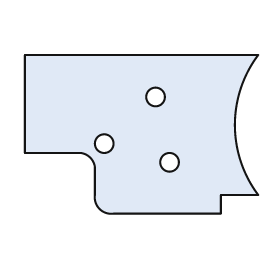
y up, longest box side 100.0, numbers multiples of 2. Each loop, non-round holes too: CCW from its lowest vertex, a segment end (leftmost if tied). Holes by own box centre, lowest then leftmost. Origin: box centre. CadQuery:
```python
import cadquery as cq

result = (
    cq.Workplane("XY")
    .moveTo(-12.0, -34.0)
    .lineTo(34.0, -34.0)
    .lineTo(34.0, -26.0)
    .lineTo(50.0, -26.0)
    .threePointArc((40.0, 4.0), (50.0, 34.0))
    .lineTo(-50.0, 34.0)
    .lineTo(-50.0, -8.0)
    .lineTo(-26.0, -8.0)
    .threePointArc((-22.0, -10.0), (-20.0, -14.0))
    .lineTo(-20.0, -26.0)
    .threePointArc((-18.0, -32.0), (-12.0, -34.0))
    .close()
    .moveTo(12.0, -12.0)
    .circle(4.0)
    .moveTo(-16.0, -4.0)
    .circle(4.0)
    .moveTo(6.0, 16.0)
    .circle(4.0)
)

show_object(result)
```